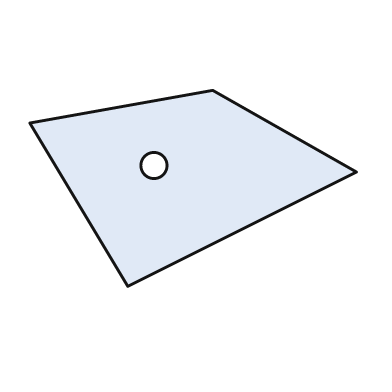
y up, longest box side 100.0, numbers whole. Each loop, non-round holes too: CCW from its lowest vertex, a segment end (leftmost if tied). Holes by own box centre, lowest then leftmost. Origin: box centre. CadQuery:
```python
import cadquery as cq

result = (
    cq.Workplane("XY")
    .moveTo(-20.0, -30.0)
    .lineTo(50.0, 5.0)
    .lineTo(6.0, 30.0)
    .lineTo(-50.0, 20.0)
    .close()
    .moveTo(-12.0, 7.0)
    .circle(4.0)
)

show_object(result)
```